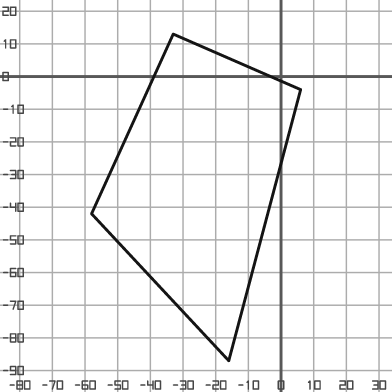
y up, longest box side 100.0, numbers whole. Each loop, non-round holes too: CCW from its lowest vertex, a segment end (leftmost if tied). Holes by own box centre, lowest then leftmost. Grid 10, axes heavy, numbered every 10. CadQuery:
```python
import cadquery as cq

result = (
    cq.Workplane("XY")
    .moveTo(-16.0, -87.0)
    .lineTo(6.0, -4.0)
    .lineTo(-33.0, 13.0)
    .lineTo(-58.0, -42.0)
    .close()
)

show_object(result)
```